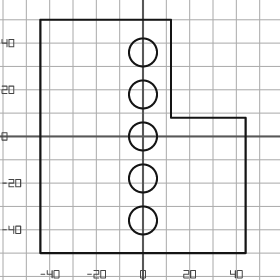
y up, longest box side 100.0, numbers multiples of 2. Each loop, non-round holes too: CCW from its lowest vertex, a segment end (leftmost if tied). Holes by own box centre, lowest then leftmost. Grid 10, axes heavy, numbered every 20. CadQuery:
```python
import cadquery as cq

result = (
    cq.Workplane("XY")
    .moveTo(-44.0, -50.0)
    .lineTo(44.0, -50.0)
    .lineTo(44.0, 8.0)
    .lineTo(12.0, 8.0)
    .lineTo(12.0, 50.0)
    .lineTo(-44.0, 50.0)
    .close()
    .moveTo(0.0, -36.0)
    .circle(6.0)
    .moveTo(0.0, -18.0)
    .circle(6.0)
    .moveTo(0.0, 0.0)
    .circle(6.0)
    .moveTo(0.0, 18.0)
    .circle(6.0)
    .moveTo(0.0, 36.0)
    .circle(6.0)
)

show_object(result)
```